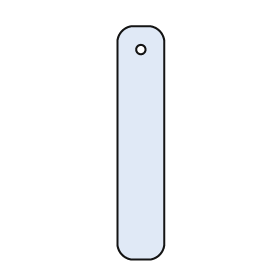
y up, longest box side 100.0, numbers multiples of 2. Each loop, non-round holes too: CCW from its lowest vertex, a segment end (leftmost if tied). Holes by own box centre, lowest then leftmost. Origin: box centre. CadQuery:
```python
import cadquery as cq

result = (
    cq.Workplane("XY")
    .moveTo(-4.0, -50.0)
    .lineTo(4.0, -50.0)
    .threePointArc((8.0, -48.0), (10.0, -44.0))
    .lineTo(10.0, 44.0)
    .threePointArc((8.0, 48.0), (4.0, 50.0))
    .lineTo(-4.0, 50.0)
    .threePointArc((-8.0, 48.0), (-10.0, 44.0))
    .lineTo(-10.0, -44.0)
    .threePointArc((-8.0, -48.0), (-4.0, -50.0))
    .close()
    .moveTo(0.0, 40.0)
    .circle(2.0)
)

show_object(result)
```